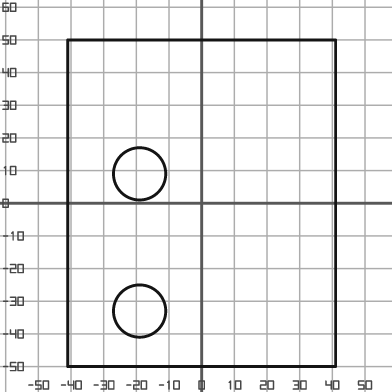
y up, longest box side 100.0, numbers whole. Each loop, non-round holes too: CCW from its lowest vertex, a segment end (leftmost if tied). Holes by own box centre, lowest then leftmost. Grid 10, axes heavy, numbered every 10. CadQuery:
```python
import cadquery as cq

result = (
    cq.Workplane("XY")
    .moveTo(-41.0, -50.0)
    .lineTo(41.0, -50.0)
    .lineTo(41.0, 50.0)
    .lineTo(-41.0, 50.0)
    .close()
    .moveTo(-19.0, -33.0)
    .circle(8.0)
    .moveTo(-19.0, 9.0)
    .circle(8.0)
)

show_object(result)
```